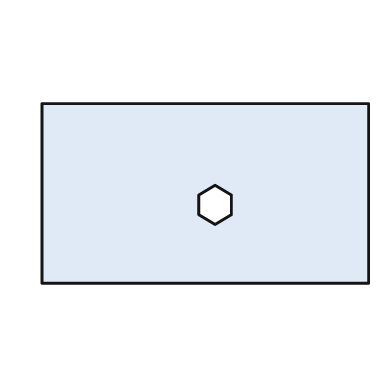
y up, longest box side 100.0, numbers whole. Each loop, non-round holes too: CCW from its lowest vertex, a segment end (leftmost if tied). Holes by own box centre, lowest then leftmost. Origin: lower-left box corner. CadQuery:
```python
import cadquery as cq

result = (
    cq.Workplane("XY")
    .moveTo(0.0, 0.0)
    .lineTo(100.0, 0.0)
    .lineTo(100.0, 55.0)
    .lineTo(0.0, 55.0)
    .close()
    .moveTo(53.0, 18.0)
    .lineTo(58.0, 21.0)
    .lineTo(58.0, 27.0)
    .lineTo(53.0, 30.0)
    .lineTo(48.0, 27.0)
    .lineTo(48.0, 21.0)
    .close()
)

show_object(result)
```